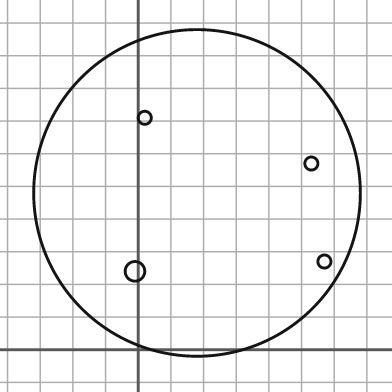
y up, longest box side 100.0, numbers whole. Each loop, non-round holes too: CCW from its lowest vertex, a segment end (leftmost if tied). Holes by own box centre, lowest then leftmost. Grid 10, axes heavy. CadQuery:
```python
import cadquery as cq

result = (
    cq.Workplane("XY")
    .moveTo(18.0, 48.0)
    .circle(50.0)
    .moveTo(-1.0, 24.0)
    .circle(3.0)
    .moveTo(57.0, 27.0)
    .circle(2.0)
    .moveTo(53.0, 57.0)
    .circle(2.0)
    .moveTo(2.0, 71.0)
    .circle(2.0)
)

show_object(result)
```